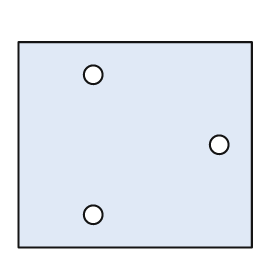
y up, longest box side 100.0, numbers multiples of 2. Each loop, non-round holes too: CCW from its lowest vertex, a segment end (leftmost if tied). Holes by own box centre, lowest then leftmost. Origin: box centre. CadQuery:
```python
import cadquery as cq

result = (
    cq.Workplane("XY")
    .moveTo(-50.0, -44.0)
    .lineTo(50.0, -44.0)
    .lineTo(50.0, 44.0)
    .lineTo(-50.0, 44.0)
    .close()
    .moveTo(-18.0, -30.0)
    .circle(4.0)
    .moveTo(36.0, 0.0)
    .circle(4.0)
    .moveTo(-18.0, 30.0)
    .circle(4.0)
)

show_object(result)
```